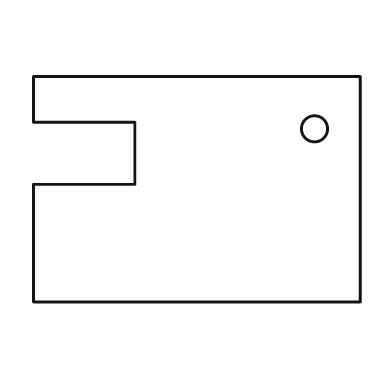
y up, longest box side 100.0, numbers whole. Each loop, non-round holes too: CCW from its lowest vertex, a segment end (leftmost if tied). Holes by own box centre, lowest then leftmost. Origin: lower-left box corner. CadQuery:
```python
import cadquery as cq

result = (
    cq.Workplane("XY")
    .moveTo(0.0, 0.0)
    .lineTo(100.0, 0.0)
    .lineTo(100.0, 69.0)
    .lineTo(0.0, 69.0)
    .lineTo(0.0, 55.0)
    .lineTo(31.0, 55.0)
    .lineTo(31.0, 36.0)
    .lineTo(0.0, 36.0)
    .close()
    .moveTo(86.0, 53.0)
    .circle(4.0)
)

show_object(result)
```